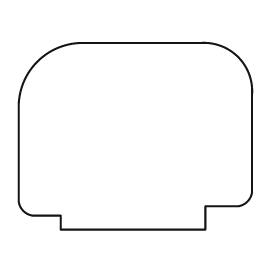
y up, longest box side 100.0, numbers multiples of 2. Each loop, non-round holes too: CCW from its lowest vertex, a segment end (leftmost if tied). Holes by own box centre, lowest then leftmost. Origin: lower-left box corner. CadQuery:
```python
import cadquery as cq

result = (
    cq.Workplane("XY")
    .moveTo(18.0, 0.0)
    .lineTo(80.0, 0.0)
    .lineTo(80.0, 10.0)
    .lineTo(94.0, 10.0)
    .threePointArc((98.0, 12.0), (100.0, 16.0))
    .lineTo(100.0, 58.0)
    .threePointArc((94.0, 74.0), (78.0, 80.0))
    .lineTo(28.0, 80.0)
    .threePointArc((8.0, 72.0), (0.0, 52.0))
    .lineTo(0.0, 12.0)
    .threePointArc((2.0, 8.0), (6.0, 6.0))
    .lineTo(18.0, 6.0)
    .close()
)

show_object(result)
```